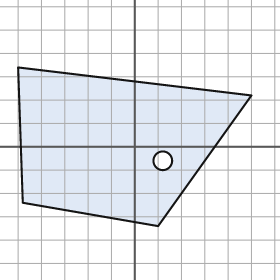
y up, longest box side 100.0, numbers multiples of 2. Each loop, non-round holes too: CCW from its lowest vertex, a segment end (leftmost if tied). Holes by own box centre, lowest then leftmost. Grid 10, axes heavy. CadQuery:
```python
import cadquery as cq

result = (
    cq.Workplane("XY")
    .moveTo(10.0, -34.0)
    .lineTo(50.0, 22.0)
    .lineTo(-50.0, 34.0)
    .lineTo(-48.0, -24.0)
    .close()
    .moveTo(12.0, -6.0)
    .circle(4.0)
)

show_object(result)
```